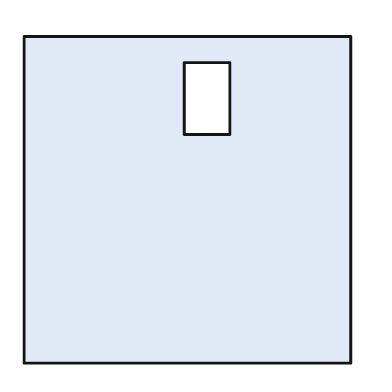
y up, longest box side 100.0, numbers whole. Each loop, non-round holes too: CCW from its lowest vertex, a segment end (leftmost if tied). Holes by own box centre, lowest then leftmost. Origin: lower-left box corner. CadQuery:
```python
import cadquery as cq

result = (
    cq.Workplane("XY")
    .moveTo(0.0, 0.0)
    .lineTo(100.0, 0.0)
    .lineTo(100.0, 100.0)
    .lineTo(0.0, 100.0)
    .close()
    .moveTo(49.0, 70.0)
    .lineTo(63.0, 70.0)
    .lineTo(63.0, 92.0)
    .lineTo(49.0, 92.0)
    .close()
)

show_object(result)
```